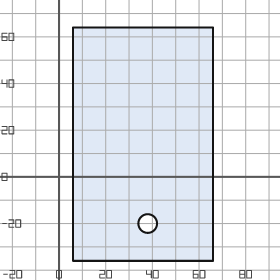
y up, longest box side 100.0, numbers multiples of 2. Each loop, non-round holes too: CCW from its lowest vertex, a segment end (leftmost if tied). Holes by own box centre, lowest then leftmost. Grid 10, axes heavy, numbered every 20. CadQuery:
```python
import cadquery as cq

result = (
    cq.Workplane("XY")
    .moveTo(6.0, -36.0)
    .lineTo(66.0, -36.0)
    .lineTo(66.0, 64.0)
    .lineTo(6.0, 64.0)
    .close()
    .moveTo(38.0, -20.0)
    .circle(4.0)
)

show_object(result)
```